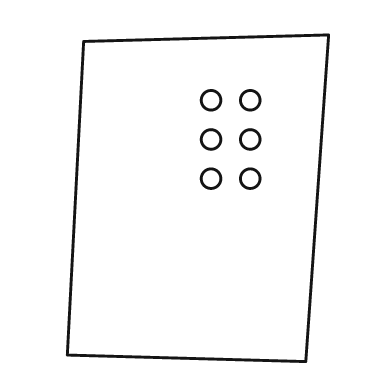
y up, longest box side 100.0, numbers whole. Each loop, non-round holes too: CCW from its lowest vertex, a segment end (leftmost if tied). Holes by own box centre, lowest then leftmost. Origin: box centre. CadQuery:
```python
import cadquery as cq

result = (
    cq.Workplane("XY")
    .moveTo(33.0, -50.0)
    .lineTo(40.0, 50.0)
    .lineTo(-35.0, 48.0)
    .lineTo(-40.0, -48.0)
    .close()
    .moveTo(4.0, 6.0)
    .circle(3.0)
    .moveTo(16.0, 6.0)
    .circle(3.0)
    .moveTo(4.0, 18.0)
    .circle(3.0)
    .moveTo(16.0, 18.0)
    .circle(3.0)
    .moveTo(4.0, 30.0)
    .circle(3.0)
    .moveTo(16.0, 30.0)
    .circle(3.0)
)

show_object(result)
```